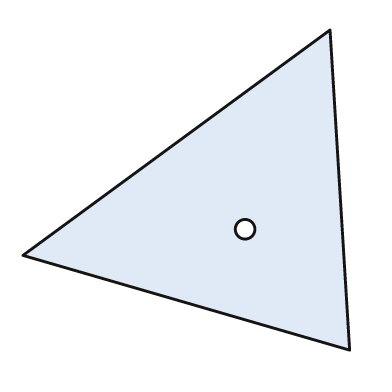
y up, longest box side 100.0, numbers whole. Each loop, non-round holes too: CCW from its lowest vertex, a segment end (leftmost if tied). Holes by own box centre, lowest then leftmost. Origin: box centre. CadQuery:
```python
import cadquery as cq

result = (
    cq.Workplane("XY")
    .moveTo(50.0, -49.0)
    .lineTo(44.0, 49.0)
    .lineTo(-50.0, -20.0)
    .close()
    .moveTo(18.0, -12.0)
    .circle(3.0)
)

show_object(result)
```